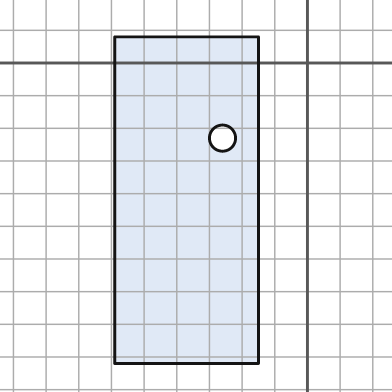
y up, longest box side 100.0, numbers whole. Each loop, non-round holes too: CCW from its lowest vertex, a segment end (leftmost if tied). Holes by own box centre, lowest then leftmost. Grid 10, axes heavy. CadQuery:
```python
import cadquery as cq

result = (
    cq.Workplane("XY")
    .moveTo(-59.0, -92.0)
    .lineTo(-15.0, -92.0)
    .lineTo(-15.0, 8.0)
    .lineTo(-59.0, 8.0)
    .close()
    .moveTo(-26.0, -23.0)
    .circle(4.0)
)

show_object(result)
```